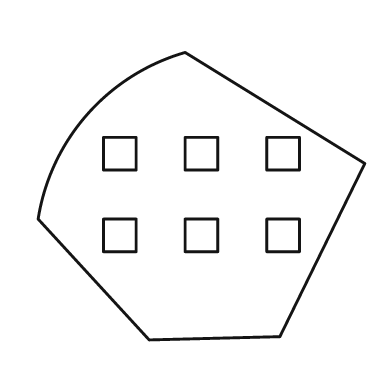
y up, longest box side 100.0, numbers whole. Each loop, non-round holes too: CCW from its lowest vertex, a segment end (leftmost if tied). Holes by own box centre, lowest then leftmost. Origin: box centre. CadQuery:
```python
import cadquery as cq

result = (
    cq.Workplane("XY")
    .moveTo(-16.0, -44.0)
    .lineTo(24.0, -43.0)
    .lineTo(50.0, 10.0)
    .lineTo(-5.0, 44.0)
    .threePointArc((-35.0, 25.0), (-50.0, -7.0))
    .close()
    .moveTo(-30.0, -17.0)
    .lineTo(-20.0, -17.0)
    .lineTo(-20.0, -7.0)
    .lineTo(-30.0, -7.0)
    .close()
    .moveTo(-5.0, -17.0)
    .lineTo(5.0, -17.0)
    .lineTo(5.0, -7.0)
    .lineTo(-5.0, -7.0)
    .close()
    .moveTo(20.0, -17.0)
    .lineTo(30.0, -17.0)
    .lineTo(30.0, -7.0)
    .lineTo(20.0, -7.0)
    .close()
    .moveTo(-30.0, 8.0)
    .lineTo(-20.0, 8.0)
    .lineTo(-20.0, 18.0)
    .lineTo(-30.0, 18.0)
    .close()
    .moveTo(-5.0, 8.0)
    .lineTo(5.0, 8.0)
    .lineTo(5.0, 18.0)
    .lineTo(-5.0, 18.0)
    .close()
    .moveTo(20.0, 8.0)
    .lineTo(30.0, 8.0)
    .lineTo(30.0, 18.0)
    .lineTo(20.0, 18.0)
    .close()
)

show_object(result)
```